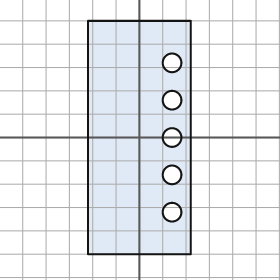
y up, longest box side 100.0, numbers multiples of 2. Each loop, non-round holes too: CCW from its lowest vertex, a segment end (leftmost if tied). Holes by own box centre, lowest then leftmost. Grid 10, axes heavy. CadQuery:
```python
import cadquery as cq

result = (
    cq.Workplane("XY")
    .moveTo(-22.0, -50.0)
    .lineTo(22.0, -50.0)
    .lineTo(22.0, 50.0)
    .lineTo(-22.0, 50.0)
    .close()
    .moveTo(14.0, -32.0)
    .circle(4.0)
    .moveTo(14.0, -16.0)
    .circle(4.0)
    .moveTo(14.0, 0.0)
    .circle(4.0)
    .moveTo(14.0, 16.0)
    .circle(4.0)
    .moveTo(14.0, 32.0)
    .circle(4.0)
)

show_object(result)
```